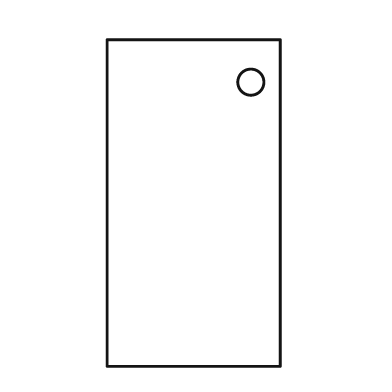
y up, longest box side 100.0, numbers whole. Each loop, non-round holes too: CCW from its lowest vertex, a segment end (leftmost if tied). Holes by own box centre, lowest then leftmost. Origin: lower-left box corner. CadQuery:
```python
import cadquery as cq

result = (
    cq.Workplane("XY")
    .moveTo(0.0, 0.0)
    .lineTo(53.0, 0.0)
    .lineTo(53.0, 100.0)
    .lineTo(0.0, 100.0)
    .close()
    .moveTo(44.0, 87.0)
    .circle(4.0)
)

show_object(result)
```